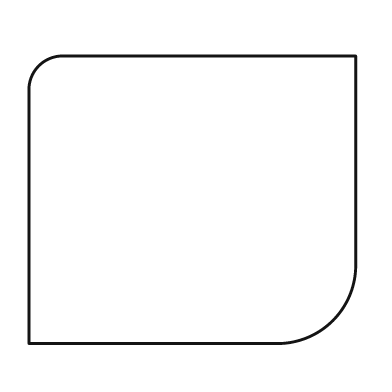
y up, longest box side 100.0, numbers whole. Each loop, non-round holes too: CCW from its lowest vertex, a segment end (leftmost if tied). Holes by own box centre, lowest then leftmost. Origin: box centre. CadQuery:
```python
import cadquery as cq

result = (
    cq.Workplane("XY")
    .moveTo(-50.0, -44.0)
    .lineTo(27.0, -44.0)
    .threePointArc((43.0, -37.0), (50.0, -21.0))
    .lineTo(50.0, 44.0)
    .lineTo(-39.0, 44.0)
    .threePointArc((-47.0, 41.0), (-50.0, 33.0))
    .close()
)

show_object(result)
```